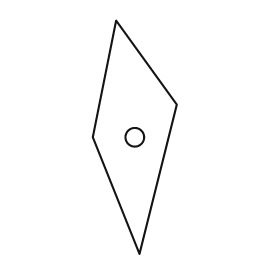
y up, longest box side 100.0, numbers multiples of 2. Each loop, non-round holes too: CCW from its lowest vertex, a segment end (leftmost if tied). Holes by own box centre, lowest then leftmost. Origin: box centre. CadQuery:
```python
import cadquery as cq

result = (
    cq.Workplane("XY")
    .moveTo(2.0, -50.0)
    .lineTo(18.0, 14.0)
    .lineTo(-8.0, 50.0)
    .lineTo(-18.0, 0.0)
    .close()
    .moveTo(0.0, 0.0)
    .circle(4.0)
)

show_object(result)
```